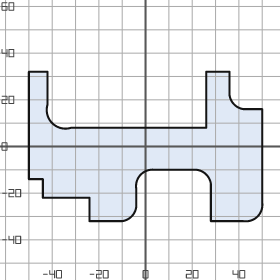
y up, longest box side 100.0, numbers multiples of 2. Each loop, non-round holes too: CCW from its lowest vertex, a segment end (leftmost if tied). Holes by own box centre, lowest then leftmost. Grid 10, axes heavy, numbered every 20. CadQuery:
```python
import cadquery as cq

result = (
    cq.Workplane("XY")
    .moveTo(-24.0, -32.0)
    .lineTo(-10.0, -32.0)
    .threePointArc((-6.0, -30.0), (-4.0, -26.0))
    .lineTo(-4.0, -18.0)
    .threePointArc((-2.0, -12.0), (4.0, -10.0))
    .lineTo(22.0, -10.0)
    .threePointArc((26.0, -12.0), (28.0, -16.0))
    .lineTo(28.0, -32.0)
    .lineTo(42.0, -32.0)
    .threePointArc((48.0, -30.0), (50.0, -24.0))
    .lineTo(50.0, 16.0)
    .lineTo(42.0, 16.0)
    .threePointArc((38.0, 18.0), (36.0, 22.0))
    .lineTo(36.0, 32.0)
    .lineTo(26.0, 32.0)
    .lineTo(26.0, 8.0)
    .lineTo(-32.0, 8.0)
    .threePointArc((-40.0, 10.0), (-42.0, 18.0))
    .lineTo(-42.0, 32.0)
    .lineTo(-50.0, 32.0)
    .lineTo(-50.0, -14.0)
    .lineTo(-44.0, -14.0)
    .lineTo(-44.0, -22.0)
    .lineTo(-24.0, -22.0)
    .close()
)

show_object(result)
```